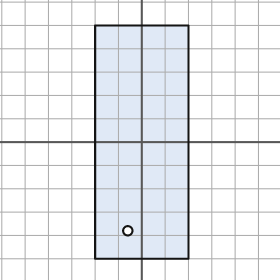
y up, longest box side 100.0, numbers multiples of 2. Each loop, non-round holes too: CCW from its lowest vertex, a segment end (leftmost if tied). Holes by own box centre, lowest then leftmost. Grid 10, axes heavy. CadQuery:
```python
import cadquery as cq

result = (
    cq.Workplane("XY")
    .moveTo(-20.0, -50.0)
    .lineTo(20.0, -50.0)
    .lineTo(20.0, 50.0)
    .lineTo(-20.0, 50.0)
    .close()
    .moveTo(-6.0, -38.0)
    .circle(2.0)
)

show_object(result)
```